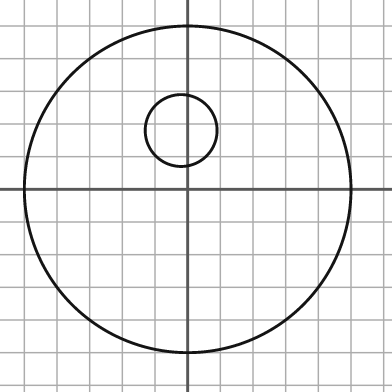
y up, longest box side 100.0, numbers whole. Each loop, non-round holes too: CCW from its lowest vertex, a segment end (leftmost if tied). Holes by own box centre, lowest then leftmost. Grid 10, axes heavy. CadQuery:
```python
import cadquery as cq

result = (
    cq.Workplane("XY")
    .moveTo(0.0, 0.0)
    .circle(50.0)
    .moveTo(-2.0, 18.0)
    .circle(11.0)
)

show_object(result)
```